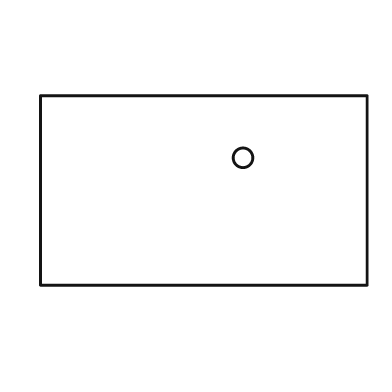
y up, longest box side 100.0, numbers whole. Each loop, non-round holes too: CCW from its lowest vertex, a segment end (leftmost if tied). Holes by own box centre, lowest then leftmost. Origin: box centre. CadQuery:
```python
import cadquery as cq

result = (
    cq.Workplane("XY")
    .moveTo(-50.0, -29.0)
    .lineTo(50.0, -29.0)
    .lineTo(50.0, 29.0)
    .lineTo(-50.0, 29.0)
    .close()
    .moveTo(12.0, 10.0)
    .circle(3.0)
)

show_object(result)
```